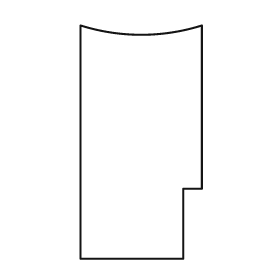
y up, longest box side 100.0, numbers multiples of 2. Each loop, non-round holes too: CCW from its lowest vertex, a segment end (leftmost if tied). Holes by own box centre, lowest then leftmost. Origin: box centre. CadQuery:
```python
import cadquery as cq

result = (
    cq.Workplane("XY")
    .moveTo(-26.0, -50.0)
    .lineTo(18.0, -50.0)
    .lineTo(18.0, -20.0)
    .lineTo(26.0, -20.0)
    .lineTo(26.0, 50.0)
    .threePointArc((0.0, 46.0), (-26.0, 50.0))
    .close()
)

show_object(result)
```